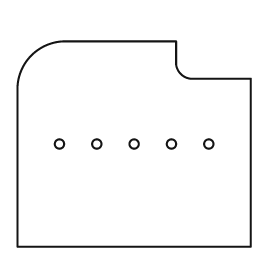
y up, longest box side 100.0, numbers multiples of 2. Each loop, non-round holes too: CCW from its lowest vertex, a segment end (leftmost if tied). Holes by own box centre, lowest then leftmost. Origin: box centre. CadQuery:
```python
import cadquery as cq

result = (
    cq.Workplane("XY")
    .moveTo(-50.0, -44.0)
    .lineTo(50.0, -44.0)
    .lineTo(50.0, 28.0)
    .lineTo(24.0, 28.0)
    .threePointArc((20.0, 30.0), (18.0, 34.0))
    .lineTo(18.0, 44.0)
    .lineTo(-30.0, 44.0)
    .threePointArc((-44.0, 38.0), (-50.0, 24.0))
    .close()
    .moveTo(-32.0, 0.0)
    .circle(2.0)
    .moveTo(-16.0, 0.0)
    .circle(2.0)
    .moveTo(0.0, 0.0)
    .circle(2.0)
    .moveTo(16.0, 0.0)
    .circle(2.0)
    .moveTo(32.0, 0.0)
    .circle(2.0)
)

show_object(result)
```